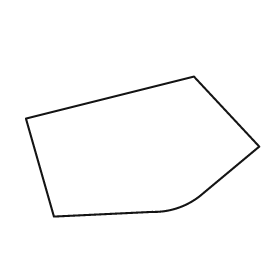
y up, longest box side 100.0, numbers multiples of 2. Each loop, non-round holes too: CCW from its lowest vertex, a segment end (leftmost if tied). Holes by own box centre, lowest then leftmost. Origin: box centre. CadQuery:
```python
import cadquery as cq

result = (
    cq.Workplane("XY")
    .moveTo(-38.0, -30.0)
    .lineTo(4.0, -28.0)
    .threePointArc((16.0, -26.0), (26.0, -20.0))
    .lineTo(50.0, 0.0)
    .lineTo(22.0, 30.0)
    .lineTo(-50.0, 12.0)
    .close()
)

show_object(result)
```